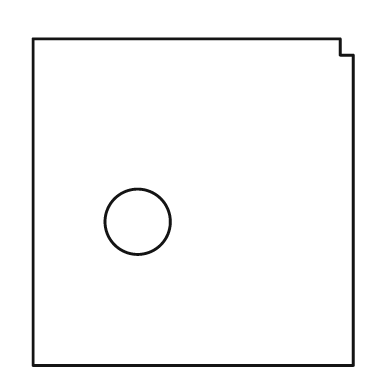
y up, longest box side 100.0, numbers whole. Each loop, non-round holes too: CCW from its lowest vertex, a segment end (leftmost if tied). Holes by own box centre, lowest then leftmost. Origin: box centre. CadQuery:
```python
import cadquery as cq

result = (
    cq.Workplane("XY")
    .moveTo(-49.0, -50.0)
    .lineTo(49.0, -50.0)
    .lineTo(49.0, 45.0)
    .lineTo(45.0, 45.0)
    .lineTo(45.0, 50.0)
    .lineTo(-49.0, 50.0)
    .close()
    .moveTo(-17.0, -6.0)
    .circle(10.0)
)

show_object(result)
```